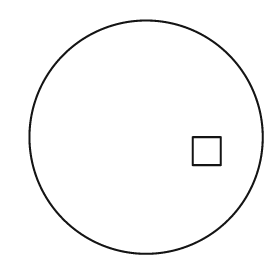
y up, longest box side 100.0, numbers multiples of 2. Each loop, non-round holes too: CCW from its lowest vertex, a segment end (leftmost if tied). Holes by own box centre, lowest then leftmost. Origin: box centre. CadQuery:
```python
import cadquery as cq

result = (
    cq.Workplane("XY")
    .moveTo(0.0, 0.0)
    .circle(50.0)
    .moveTo(20.0, -12.0)
    .lineTo(32.0, -12.0)
    .lineTo(32.0, 0.0)
    .lineTo(20.0, 0.0)
    .close()
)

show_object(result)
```